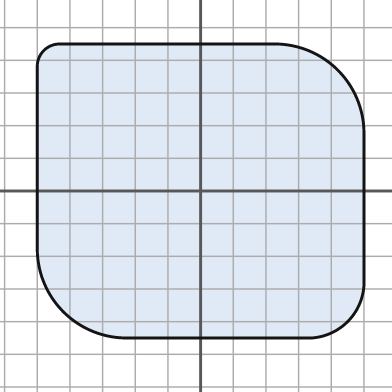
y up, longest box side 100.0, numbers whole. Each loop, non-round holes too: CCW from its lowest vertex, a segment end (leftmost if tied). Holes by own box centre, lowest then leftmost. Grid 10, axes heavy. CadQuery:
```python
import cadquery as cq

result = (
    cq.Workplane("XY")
    .moveTo(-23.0, -45.0)
    .lineTo(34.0, -45.0)
    .threePointArc((45.0, -40.0), (50.0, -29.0))
    .lineTo(50.0, 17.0)
    .threePointArc((42.0, 37.0), (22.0, 45.0))
    .lineTo(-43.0, 45.0)
    .threePointArc((-48.0, 43.0), (-50.0, 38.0))
    .lineTo(-50.0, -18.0)
    .threePointArc((-42.0, -37.0), (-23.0, -45.0))
    .close()
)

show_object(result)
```